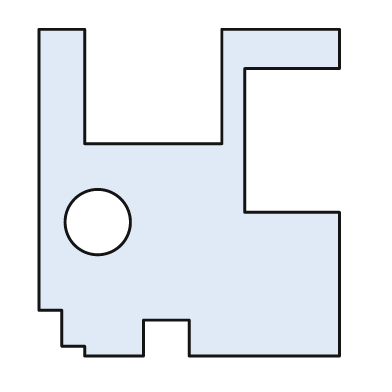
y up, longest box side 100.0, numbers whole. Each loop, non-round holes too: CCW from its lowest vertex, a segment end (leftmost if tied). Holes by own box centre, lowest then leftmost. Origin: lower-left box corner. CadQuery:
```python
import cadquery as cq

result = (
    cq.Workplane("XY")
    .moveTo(14.0, 0.0)
    .lineTo(32.0, 0.0)
    .lineTo(32.0, 11.0)
    .lineTo(46.0, 11.0)
    .lineTo(46.0, 0.0)
    .lineTo(92.0, 0.0)
    .lineTo(92.0, 44.0)
    .lineTo(63.0, 44.0)
    .lineTo(63.0, 88.0)
    .lineTo(92.0, 88.0)
    .lineTo(92.0, 100.0)
    .lineTo(56.0, 100.0)
    .lineTo(56.0, 65.0)
    .lineTo(14.0, 65.0)
    .lineTo(14.0, 100.0)
    .lineTo(0.0, 100.0)
    .lineTo(0.0, 14.0)
    .lineTo(7.0, 14.0)
    .lineTo(7.0, 3.0)
    .lineTo(14.0, 3.0)
    .close()
    .moveTo(18.0, 41.0)
    .circle(10.0)
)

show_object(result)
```